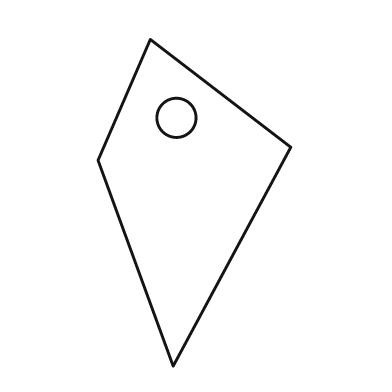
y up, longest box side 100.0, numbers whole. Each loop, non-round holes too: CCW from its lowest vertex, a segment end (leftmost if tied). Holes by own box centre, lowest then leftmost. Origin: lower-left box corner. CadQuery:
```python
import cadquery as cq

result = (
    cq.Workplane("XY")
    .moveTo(23.0, 0.0)
    .lineTo(59.0, 67.0)
    .lineTo(16.0, 100.0)
    .lineTo(0.0, 63.0)
    .close()
    .moveTo(24.0, 76.0)
    .circle(6.0)
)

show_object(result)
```